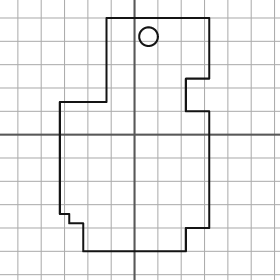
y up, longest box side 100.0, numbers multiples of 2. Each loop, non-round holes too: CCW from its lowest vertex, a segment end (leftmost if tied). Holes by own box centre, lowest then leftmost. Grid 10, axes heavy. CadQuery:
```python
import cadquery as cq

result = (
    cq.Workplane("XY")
    .moveTo(-22.0, -50.0)
    .lineTo(22.0, -50.0)
    .lineTo(22.0, -40.0)
    .lineTo(32.0, -40.0)
    .lineTo(32.0, 10.0)
    .lineTo(22.0, 10.0)
    .lineTo(22.0, 24.0)
    .lineTo(32.0, 24.0)
    .lineTo(32.0, 50.0)
    .lineTo(-12.0, 50.0)
    .lineTo(-12.0, 14.0)
    .lineTo(-32.0, 14.0)
    .lineTo(-32.0, -34.0)
    .lineTo(-28.0, -34.0)
    .lineTo(-28.0, -38.0)
    .lineTo(-22.0, -38.0)
    .close()
    .moveTo(6.0, 42.0)
    .circle(4.0)
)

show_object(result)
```